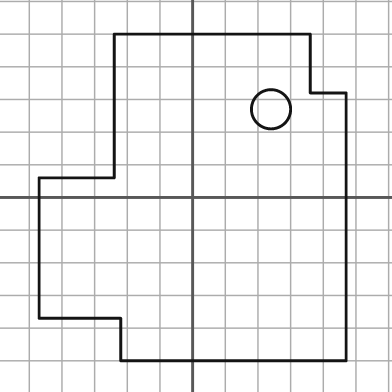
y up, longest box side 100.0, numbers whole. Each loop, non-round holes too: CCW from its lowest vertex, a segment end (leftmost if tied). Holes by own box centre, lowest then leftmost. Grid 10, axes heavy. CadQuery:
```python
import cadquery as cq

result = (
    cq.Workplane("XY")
    .moveTo(-22.0, -50.0)
    .lineTo(47.0, -50.0)
    .lineTo(47.0, 32.0)
    .lineTo(36.0, 32.0)
    .lineTo(36.0, 50.0)
    .lineTo(-24.0, 50.0)
    .lineTo(-24.0, 6.0)
    .lineTo(-47.0, 6.0)
    .lineTo(-47.0, -37.0)
    .lineTo(-22.0, -37.0)
    .close()
    .moveTo(24.0, 27.0)
    .circle(6.0)
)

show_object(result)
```